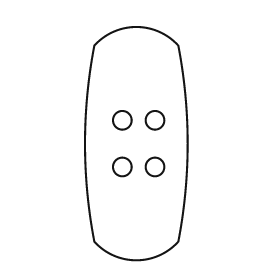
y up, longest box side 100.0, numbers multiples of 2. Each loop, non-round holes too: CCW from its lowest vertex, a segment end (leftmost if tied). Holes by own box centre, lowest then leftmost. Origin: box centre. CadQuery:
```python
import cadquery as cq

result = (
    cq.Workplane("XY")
    .moveTo(-18.0, -42.0)
    .threePointArc((0.0, -50.0), (18.0, -42.0))
    .threePointArc((22.0, 0.0), (18.0, 42.0))
    .threePointArc((0.0, 50.0), (-18.0, 42.0))
    .threePointArc((-22.0, 0.0), (-18.0, -42.0))
    .close()
    .moveTo(-6.0, -10.0)
    .circle(4.0)
    .moveTo(8.0, -10.0)
    .circle(4.0)
    .moveTo(-6.0, 10.0)
    .circle(4.0)
    .moveTo(8.0, 10.0)
    .circle(4.0)
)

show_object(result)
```